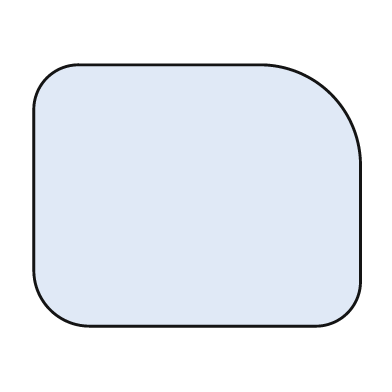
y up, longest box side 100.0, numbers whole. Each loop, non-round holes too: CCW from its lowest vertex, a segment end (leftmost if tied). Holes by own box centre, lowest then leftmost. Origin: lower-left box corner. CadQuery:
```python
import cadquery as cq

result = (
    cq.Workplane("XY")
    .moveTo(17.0, 0.0)
    .lineTo(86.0, 0.0)
    .threePointArc((96.0, 4.0), (100.0, 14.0))
    .lineTo(100.0, 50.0)
    .threePointArc((91.0, 71.0), (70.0, 80.0))
    .lineTo(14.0, 80.0)
    .threePointArc((4.0, 76.0), (0.0, 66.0))
    .lineTo(0.0, 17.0)
    .threePointArc((5.0, 5.0), (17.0, 0.0))
    .close()
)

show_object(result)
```